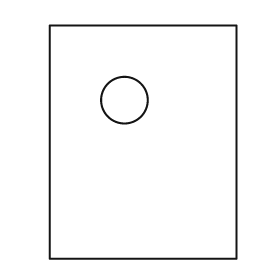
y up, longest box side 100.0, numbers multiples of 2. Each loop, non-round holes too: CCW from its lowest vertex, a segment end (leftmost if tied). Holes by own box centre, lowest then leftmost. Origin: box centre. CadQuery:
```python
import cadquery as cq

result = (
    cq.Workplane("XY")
    .moveTo(-40.0, -50.0)
    .lineTo(40.0, -50.0)
    .lineTo(40.0, 50.0)
    .lineTo(-40.0, 50.0)
    .close()
    .moveTo(-8.0, 18.0)
    .circle(10.0)
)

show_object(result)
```